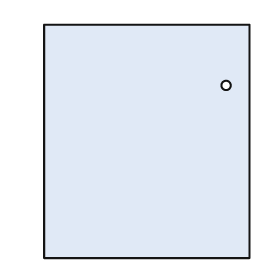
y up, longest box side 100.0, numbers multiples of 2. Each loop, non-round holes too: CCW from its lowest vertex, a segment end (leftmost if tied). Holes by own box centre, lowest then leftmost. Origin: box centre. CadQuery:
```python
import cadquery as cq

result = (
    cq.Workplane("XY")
    .moveTo(-44.0, -50.0)
    .lineTo(44.0, -50.0)
    .lineTo(44.0, 50.0)
    .lineTo(-44.0, 50.0)
    .close()
    .moveTo(34.0, 24.0)
    .circle(2.0)
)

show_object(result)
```